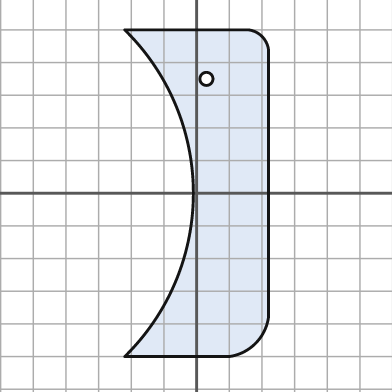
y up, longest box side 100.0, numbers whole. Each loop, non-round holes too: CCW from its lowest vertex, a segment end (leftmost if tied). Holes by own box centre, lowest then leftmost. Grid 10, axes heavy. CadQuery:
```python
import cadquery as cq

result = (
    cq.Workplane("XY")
    .moveTo(-22.0, -50.0)
    .lineTo(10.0, -50.0)
    .threePointArc((18.0, -46.0), (22.0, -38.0))
    .lineTo(22.0, 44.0)
    .threePointArc((20.0, 48.0), (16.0, 50.0))
    .lineTo(-22.0, 50.0)
    .threePointArc((-1.0, 0.0), (-22.0, -50.0))
    .close()
    .moveTo(3.0, 35.0)
    .circle(2.0)
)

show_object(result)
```